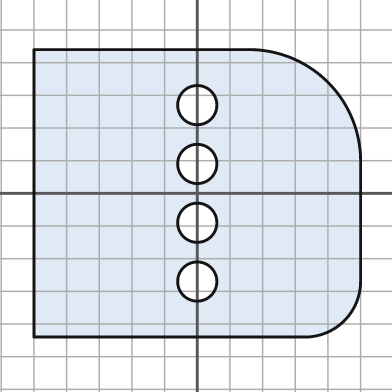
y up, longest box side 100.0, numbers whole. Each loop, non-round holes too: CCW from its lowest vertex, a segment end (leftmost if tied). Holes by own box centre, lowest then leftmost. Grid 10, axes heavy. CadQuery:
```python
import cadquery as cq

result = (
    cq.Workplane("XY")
    .moveTo(-50.0, -44.0)
    .lineTo(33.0, -44.0)
    .threePointArc((45.0, -39.0), (50.0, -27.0))
    .lineTo(50.0, 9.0)
    .threePointArc((40.0, 34.0), (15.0, 44.0))
    .lineTo(-50.0, 44.0)
    .close()
    .moveTo(0.0, -27.0)
    .circle(6.0)
    .moveTo(0.0, -9.0)
    .circle(6.0)
    .moveTo(0.0, 9.0)
    .circle(6.0)
    .moveTo(0.0, 27.0)
    .circle(6.0)
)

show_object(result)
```